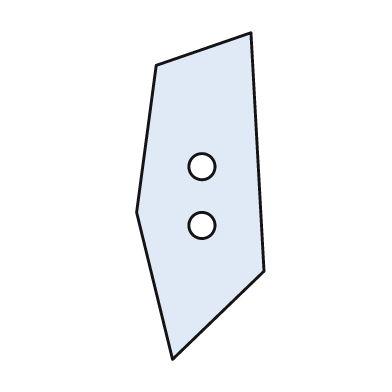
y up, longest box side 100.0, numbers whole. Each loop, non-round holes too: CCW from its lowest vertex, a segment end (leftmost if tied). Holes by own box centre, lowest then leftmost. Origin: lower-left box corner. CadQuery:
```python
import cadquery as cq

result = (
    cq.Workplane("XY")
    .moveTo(11.0, 0.0)
    .lineTo(39.0, 27.0)
    .lineTo(35.0, 100.0)
    .lineTo(6.0, 90.0)
    .lineTo(0.0, 45.0)
    .close()
    .moveTo(20.0, 41.0)
    .circle(4.0)
    .moveTo(20.0, 59.0)
    .circle(4.0)
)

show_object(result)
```